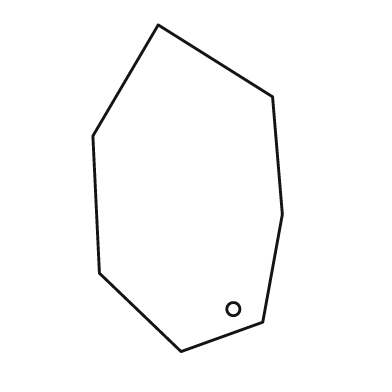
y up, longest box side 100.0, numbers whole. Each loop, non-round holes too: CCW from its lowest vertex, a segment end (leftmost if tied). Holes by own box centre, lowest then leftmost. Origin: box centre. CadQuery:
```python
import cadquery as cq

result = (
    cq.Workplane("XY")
    .moveTo(-2.0, -50.0)
    .lineTo(23.0, -41.0)
    .lineTo(29.0, -8.0)
    .lineTo(26.0, 28.0)
    .lineTo(-9.0, 50.0)
    .lineTo(-29.0, 16.0)
    .lineTo(-27.0, -26.0)
    .close()
    .moveTo(14.0, -37.0)
    .circle(2.0)
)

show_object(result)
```